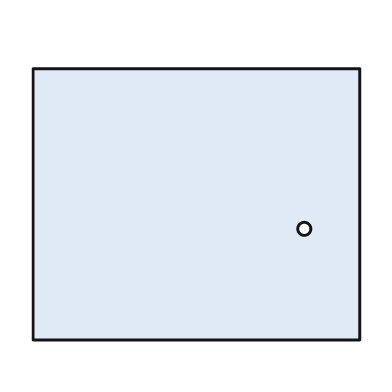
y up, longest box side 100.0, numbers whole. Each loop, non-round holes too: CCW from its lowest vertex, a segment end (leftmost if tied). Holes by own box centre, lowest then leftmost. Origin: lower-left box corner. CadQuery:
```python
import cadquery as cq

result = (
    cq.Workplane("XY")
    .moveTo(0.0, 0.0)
    .lineTo(100.0, 0.0)
    .lineTo(100.0, 83.0)
    .lineTo(0.0, 83.0)
    .close()
    .moveTo(83.0, 34.0)
    .circle(2.0)
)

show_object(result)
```